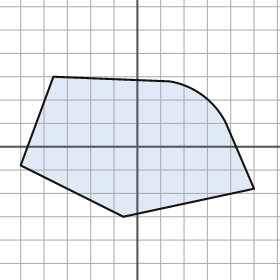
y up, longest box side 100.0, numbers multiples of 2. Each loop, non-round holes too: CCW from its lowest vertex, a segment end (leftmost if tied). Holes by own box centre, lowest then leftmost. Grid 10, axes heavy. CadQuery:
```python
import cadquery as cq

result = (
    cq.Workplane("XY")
    .moveTo(-6.0, -30.0)
    .lineTo(50.0, -18.0)
    .lineTo(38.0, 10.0)
    .threePointArc((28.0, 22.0), (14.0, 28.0))
    .lineTo(-36.0, 30.0)
    .lineTo(-50.0, -8.0)
    .close()
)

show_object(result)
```